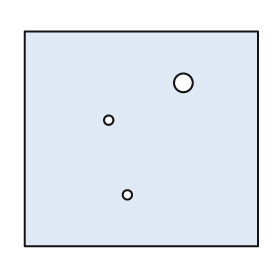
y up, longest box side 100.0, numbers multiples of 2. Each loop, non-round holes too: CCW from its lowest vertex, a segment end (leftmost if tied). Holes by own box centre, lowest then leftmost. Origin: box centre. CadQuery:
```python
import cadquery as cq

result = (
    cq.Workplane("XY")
    .moveTo(-50.0, -46.0)
    .lineTo(50.0, -46.0)
    .lineTo(50.0, 46.0)
    .lineTo(-50.0, 46.0)
    .close()
    .moveTo(-6.0, -24.0)
    .circle(2.0)
    .moveTo(-14.0, 8.0)
    .circle(2.0)
    .moveTo(18.0, 24.0)
    .circle(4.0)
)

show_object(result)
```